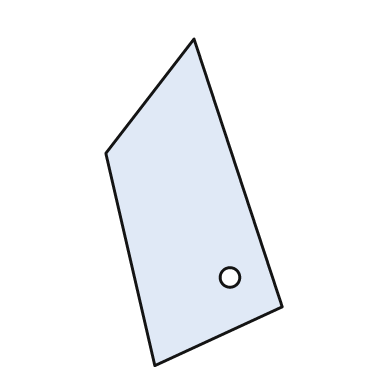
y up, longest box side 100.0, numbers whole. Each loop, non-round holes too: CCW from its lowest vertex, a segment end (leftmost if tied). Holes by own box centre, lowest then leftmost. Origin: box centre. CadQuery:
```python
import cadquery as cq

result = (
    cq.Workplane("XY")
    .moveTo(-12.0, -50.0)
    .lineTo(27.0, -32.0)
    .lineTo(0.0, 50.0)
    .lineTo(-27.0, 15.0)
    .close()
    .moveTo(11.0, -23.0)
    .circle(3.0)
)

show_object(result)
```